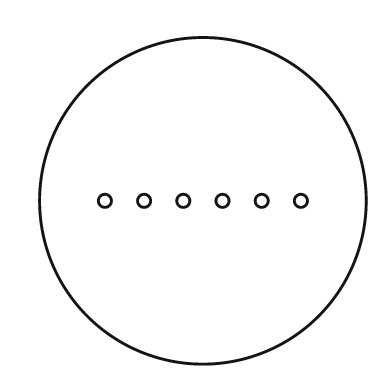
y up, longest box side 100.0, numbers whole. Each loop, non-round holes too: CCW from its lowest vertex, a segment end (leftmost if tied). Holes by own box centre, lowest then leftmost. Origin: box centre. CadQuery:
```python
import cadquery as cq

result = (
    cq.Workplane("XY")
    .moveTo(0.0, 0.0)
    .circle(50.0)
    .moveTo(-30.0, 0.0)
    .circle(2.0)
    .moveTo(-18.0, 0.0)
    .circle(2.0)
    .moveTo(-6.0, 0.0)
    .circle(2.0)
    .moveTo(6.0, 0.0)
    .circle(2.0)
    .moveTo(18.0, 0.0)
    .circle(2.0)
    .moveTo(30.0, 0.0)
    .circle(2.0)
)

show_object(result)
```